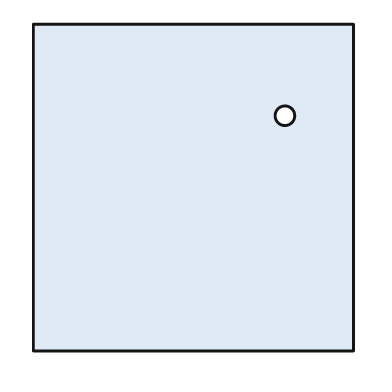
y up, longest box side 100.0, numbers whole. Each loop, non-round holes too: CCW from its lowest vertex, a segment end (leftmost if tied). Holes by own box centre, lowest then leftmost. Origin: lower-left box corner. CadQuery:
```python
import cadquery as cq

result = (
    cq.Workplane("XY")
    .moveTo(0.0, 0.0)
    .lineTo(98.0, 0.0)
    .lineTo(98.0, 100.0)
    .lineTo(0.0, 100.0)
    .close()
    .moveTo(77.0, 72.0)
    .circle(3.0)
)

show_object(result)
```